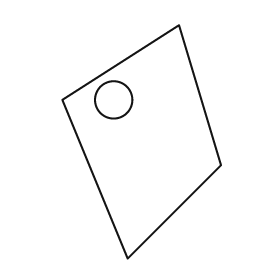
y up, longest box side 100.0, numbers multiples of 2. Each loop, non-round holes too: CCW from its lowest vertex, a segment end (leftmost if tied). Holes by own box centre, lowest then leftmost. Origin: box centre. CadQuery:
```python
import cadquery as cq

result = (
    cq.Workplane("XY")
    .moveTo(-6.0, -50.0)
    .lineTo(34.0, -10.0)
    .lineTo(16.0, 50.0)
    .lineTo(-34.0, 18.0)
    .close()
    .moveTo(-12.0, 18.0)
    .circle(8.0)
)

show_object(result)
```